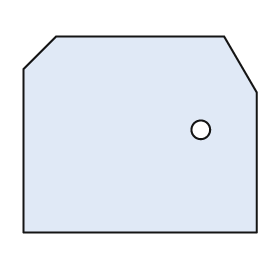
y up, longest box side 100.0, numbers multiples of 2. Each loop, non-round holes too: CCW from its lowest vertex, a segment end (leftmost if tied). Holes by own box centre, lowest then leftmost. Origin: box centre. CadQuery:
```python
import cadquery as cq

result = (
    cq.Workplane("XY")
    .moveTo(-50.0, -42.0)
    .lineTo(50.0, -42.0)
    .lineTo(50.0, 18.0)
    .lineTo(36.0, 42.0)
    .lineTo(-36.0, 42.0)
    .lineTo(-50.0, 28.0)
    .close()
    .moveTo(26.0, 2.0)
    .circle(4.0)
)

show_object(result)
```